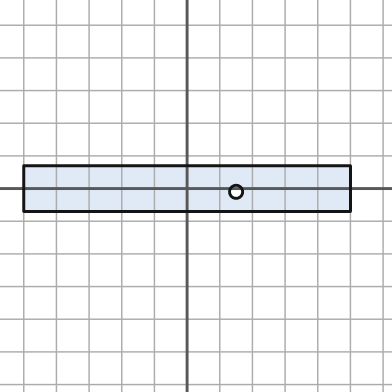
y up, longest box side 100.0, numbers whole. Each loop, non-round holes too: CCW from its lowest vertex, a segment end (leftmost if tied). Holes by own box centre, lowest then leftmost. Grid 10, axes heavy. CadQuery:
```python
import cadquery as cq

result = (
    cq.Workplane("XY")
    .moveTo(-50.0, -7.0)
    .lineTo(50.0, -7.0)
    .lineTo(50.0, 7.0)
    .lineTo(-50.0, 7.0)
    .close()
    .moveTo(15.0, -1.0)
    .circle(2.0)
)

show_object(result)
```